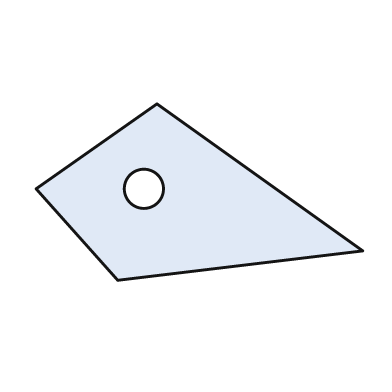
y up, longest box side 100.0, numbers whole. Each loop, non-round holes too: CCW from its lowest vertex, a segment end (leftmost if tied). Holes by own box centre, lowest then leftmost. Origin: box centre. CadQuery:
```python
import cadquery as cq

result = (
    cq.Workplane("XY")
    .moveTo(-25.0, -27.0)
    .lineTo(50.0, -18.0)
    .lineTo(-13.0, 27.0)
    .lineTo(-50.0, 1.0)
    .close()
    .moveTo(-17.0, 1.0)
    .circle(6.0)
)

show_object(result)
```